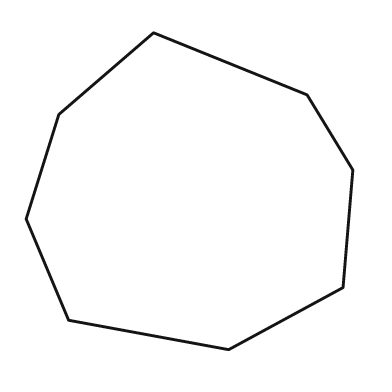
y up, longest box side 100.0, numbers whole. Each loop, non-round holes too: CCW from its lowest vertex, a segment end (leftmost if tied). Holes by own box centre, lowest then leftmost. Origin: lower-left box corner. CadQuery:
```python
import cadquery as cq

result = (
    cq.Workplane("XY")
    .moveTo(62.0, 0.0)
    .lineTo(97.0, 19.0)
    .lineTo(100.0, 55.0)
    .lineTo(86.0, 78.0)
    .lineTo(39.0, 97.0)
    .lineTo(10.0, 72.0)
    .lineTo(0.0, 40.0)
    .lineTo(13.0, 9.0)
    .close()
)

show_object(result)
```